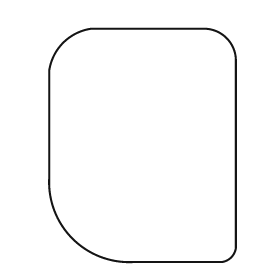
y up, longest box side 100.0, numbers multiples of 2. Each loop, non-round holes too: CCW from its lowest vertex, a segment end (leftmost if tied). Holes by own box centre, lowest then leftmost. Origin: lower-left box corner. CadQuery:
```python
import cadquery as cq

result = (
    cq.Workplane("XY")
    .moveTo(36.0, 0.0)
    .lineTo(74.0, 0.0)
    .threePointArc((78.0, 2.0), (80.0, 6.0))
    .lineTo(80.0, 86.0)
    .threePointArc((76.0, 96.0), (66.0, 100.0))
    .lineTo(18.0, 100.0)
    .threePointArc((6.0, 94.0), (0.0, 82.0))
    .lineTo(0.0, 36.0)
    .threePointArc((10.0, 10.0), (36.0, 0.0))
    .close()
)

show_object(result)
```